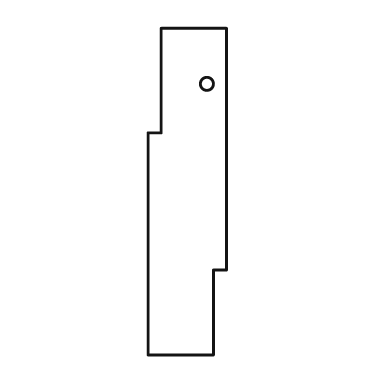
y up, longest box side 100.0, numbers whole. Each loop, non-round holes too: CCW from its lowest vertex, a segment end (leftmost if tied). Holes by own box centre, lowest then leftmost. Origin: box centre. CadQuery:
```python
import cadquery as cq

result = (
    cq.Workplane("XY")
    .moveTo(-12.0, -50.0)
    .lineTo(8.0, -50.0)
    .lineTo(8.0, -24.0)
    .lineTo(12.0, -24.0)
    .lineTo(12.0, 50.0)
    .lineTo(-8.0, 50.0)
    .lineTo(-8.0, 18.0)
    .lineTo(-12.0, 18.0)
    .close()
    .moveTo(6.0, 33.0)
    .circle(2.0)
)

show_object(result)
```